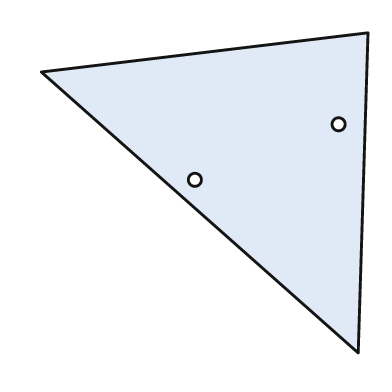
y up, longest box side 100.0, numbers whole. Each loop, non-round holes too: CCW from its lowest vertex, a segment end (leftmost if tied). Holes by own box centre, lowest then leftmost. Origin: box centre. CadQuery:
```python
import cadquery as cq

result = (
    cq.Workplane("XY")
    .moveTo(47.0, -49.0)
    .lineTo(50.0, 49.0)
    .lineTo(-50.0, 37.0)
    .close()
    .moveTo(-3.0, 4.0)
    .circle(2.0)
    .moveTo(41.0, 21.0)
    .circle(2.0)
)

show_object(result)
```